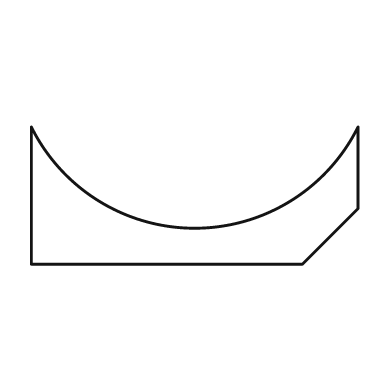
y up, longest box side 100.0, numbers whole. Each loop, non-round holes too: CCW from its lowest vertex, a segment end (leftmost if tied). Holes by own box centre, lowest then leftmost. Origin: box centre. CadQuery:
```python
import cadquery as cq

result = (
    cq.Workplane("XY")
    .moveTo(-50.0, -21.0)
    .lineTo(33.0, -21.0)
    .lineTo(50.0, -4.0)
    .lineTo(50.0, 21.0)
    .threePointArc((0.0, -10.0), (-50.0, 21.0))
    .close()
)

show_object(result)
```